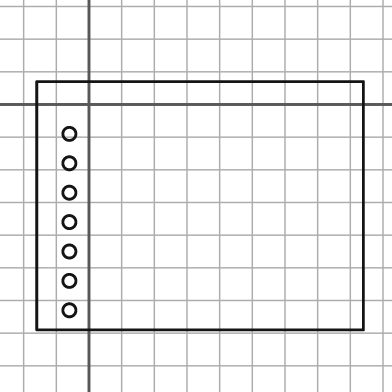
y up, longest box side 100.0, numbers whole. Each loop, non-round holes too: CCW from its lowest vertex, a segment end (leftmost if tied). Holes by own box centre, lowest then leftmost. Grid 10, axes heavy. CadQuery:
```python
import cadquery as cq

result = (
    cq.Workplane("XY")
    .moveTo(-16.0, -69.0)
    .lineTo(84.0, -69.0)
    .lineTo(84.0, 7.0)
    .lineTo(-16.0, 7.0)
    .close()
    .moveTo(-6.0, -63.0)
    .circle(2.0)
    .moveTo(-6.0, -54.0)
    .circle(2.0)
    .moveTo(-6.0, -45.0)
    .circle(2.0)
    .moveTo(-6.0, -36.0)
    .circle(2.0)
    .moveTo(-6.0, -27.0)
    .circle(2.0)
    .moveTo(-6.0, -18.0)
    .circle(2.0)
    .moveTo(-6.0, -9.0)
    .circle(2.0)
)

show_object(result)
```